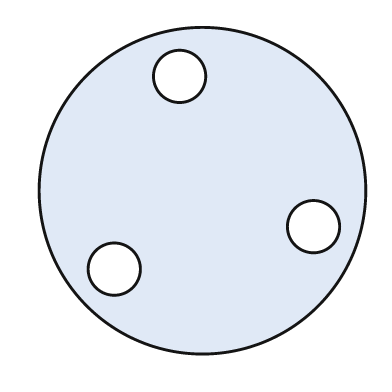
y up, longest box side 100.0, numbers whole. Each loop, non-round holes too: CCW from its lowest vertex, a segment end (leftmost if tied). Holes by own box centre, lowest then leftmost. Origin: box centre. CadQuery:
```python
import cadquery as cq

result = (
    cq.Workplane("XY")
    .moveTo(0.0, 0.0)
    .circle(50.0)
    .moveTo(-27.0, -24.0)
    .circle(8.0)
    .moveTo(34.0, -11.0)
    .circle(8.0)
    .moveTo(-7.0, 35.0)
    .circle(8.0)
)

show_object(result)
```